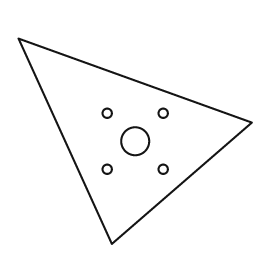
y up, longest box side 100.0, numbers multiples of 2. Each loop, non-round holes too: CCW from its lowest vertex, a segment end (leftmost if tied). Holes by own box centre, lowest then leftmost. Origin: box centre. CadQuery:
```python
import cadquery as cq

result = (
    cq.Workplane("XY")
    .moveTo(-10.0, -44.0)
    .lineTo(50.0, 8.0)
    .lineTo(-50.0, 44.0)
    .close()
    .moveTo(-12.0, -12.0)
    .circle(2.0)
    .moveTo(12.0, -12.0)
    .circle(2.0)
    .moveTo(0.0, 0.0)
    .circle(6.0)
    .moveTo(-12.0, 12.0)
    .circle(2.0)
    .moveTo(12.0, 12.0)
    .circle(2.0)
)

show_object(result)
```